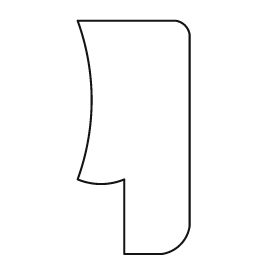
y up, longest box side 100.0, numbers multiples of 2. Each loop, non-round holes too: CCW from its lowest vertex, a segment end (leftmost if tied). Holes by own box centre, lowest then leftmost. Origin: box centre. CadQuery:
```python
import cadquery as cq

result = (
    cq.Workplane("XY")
    .moveTo(-4.0, -50.0)
    .lineTo(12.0, -50.0)
    .threePointArc((20.0, -46.0), (24.0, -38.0))
    .lineTo(24.0, 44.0)
    .threePointArc((22.0, 48.0), (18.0, 50.0))
    .lineTo(-24.0, 50.0)
    .threePointArc((-18.0, 16.0), (-24.0, -18.0))
    .threePointArc((-14.0, -20.0), (-4.0, -18.0))
    .close()
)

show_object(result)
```